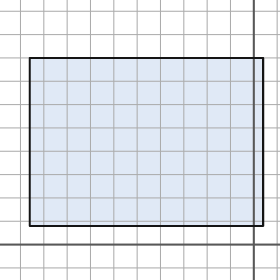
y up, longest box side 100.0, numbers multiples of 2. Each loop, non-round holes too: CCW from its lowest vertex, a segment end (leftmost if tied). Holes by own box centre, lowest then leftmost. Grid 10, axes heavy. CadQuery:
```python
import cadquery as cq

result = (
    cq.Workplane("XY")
    .moveTo(-96.0, 8.0)
    .lineTo(4.0, 8.0)
    .lineTo(4.0, 80.0)
    .lineTo(-96.0, 80.0)
    .close()
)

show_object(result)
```